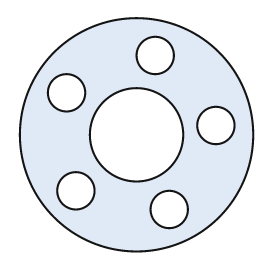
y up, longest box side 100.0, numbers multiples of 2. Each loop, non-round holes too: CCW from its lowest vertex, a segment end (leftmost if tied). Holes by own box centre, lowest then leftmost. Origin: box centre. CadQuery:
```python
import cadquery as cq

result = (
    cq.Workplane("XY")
    .moveTo(0.0, 0.0)
    .circle(50.0)
    .moveTo(14.0, -32.0)
    .circle(8.0)
    .moveTo(-26.0, -24.0)
    .circle(8.0)
    .moveTo(0.0, 0.0)
    .circle(20.0)
    .moveTo(34.0, 4.0)
    .circle(8.0)
    .moveTo(-30.0, 18.0)
    .circle(8.0)
    .moveTo(8.0, 34.0)
    .circle(8.0)
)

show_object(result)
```